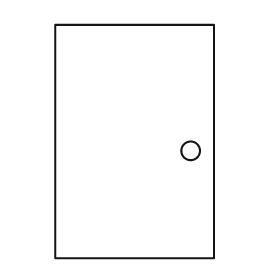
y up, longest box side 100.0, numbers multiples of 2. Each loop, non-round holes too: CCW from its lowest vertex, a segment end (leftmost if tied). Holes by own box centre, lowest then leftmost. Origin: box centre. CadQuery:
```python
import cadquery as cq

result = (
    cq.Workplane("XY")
    .moveTo(-34.0, -50.0)
    .lineTo(34.0, -50.0)
    .lineTo(34.0, 50.0)
    .lineTo(-34.0, 50.0)
    .close()
    .moveTo(24.0, -4.0)
    .circle(4.0)
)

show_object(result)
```